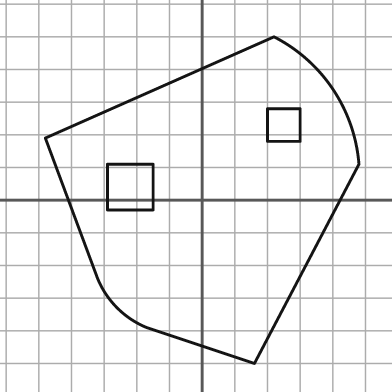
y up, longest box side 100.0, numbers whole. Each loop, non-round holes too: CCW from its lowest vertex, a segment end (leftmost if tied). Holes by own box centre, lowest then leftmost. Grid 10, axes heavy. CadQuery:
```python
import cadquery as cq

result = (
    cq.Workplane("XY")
    .moveTo(16.0, -50.0)
    .lineTo(48.0, 11.0)
    .threePointArc((40.0, 34.0), (22.0, 50.0))
    .lineTo(-48.0, 19.0)
    .lineTo(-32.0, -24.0)
    .threePointArc((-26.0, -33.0), (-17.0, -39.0))
    .close()
    .moveTo(-29.0, -3.0)
    .lineTo(-15.0, -3.0)
    .lineTo(-15.0, 11.0)
    .lineTo(-29.0, 11.0)
    .close()
    .moveTo(20.0, 18.0)
    .lineTo(30.0, 18.0)
    .lineTo(30.0, 28.0)
    .lineTo(20.0, 28.0)
    .close()
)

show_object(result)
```